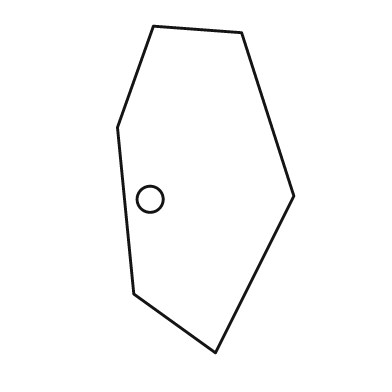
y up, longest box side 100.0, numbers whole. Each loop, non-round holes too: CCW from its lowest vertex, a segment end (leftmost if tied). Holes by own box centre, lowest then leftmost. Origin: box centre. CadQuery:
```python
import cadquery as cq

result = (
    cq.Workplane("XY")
    .moveTo(3.0, -50.0)
    .lineTo(27.0, -2.0)
    .lineTo(11.0, 48.0)
    .lineTo(-16.0, 50.0)
    .lineTo(-27.0, 19.0)
    .lineTo(-22.0, -32.0)
    .close()
    .moveTo(-17.0, -3.0)
    .circle(4.0)
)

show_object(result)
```